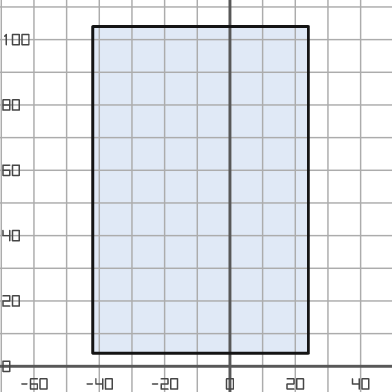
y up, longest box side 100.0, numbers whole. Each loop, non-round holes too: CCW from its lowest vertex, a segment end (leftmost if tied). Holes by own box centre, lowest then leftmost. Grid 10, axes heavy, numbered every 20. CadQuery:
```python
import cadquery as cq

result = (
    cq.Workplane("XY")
    .moveTo(-42.0, 4.0)
    .lineTo(24.0, 4.0)
    .lineTo(24.0, 104.0)
    .lineTo(-42.0, 104.0)
    .close()
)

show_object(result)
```